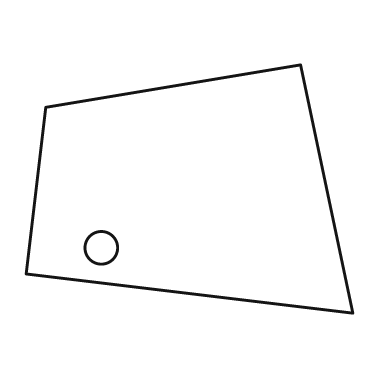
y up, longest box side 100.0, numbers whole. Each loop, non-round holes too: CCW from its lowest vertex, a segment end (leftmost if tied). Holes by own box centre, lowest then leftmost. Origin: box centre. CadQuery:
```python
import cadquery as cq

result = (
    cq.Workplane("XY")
    .moveTo(50.0, -38.0)
    .lineTo(34.0, 38.0)
    .lineTo(-44.0, 25.0)
    .lineTo(-50.0, -26.0)
    .close()
    .moveTo(-27.0, -18.0)
    .circle(5.0)
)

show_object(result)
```